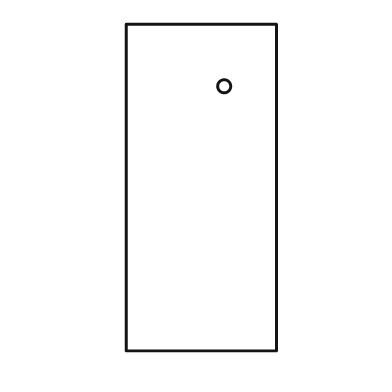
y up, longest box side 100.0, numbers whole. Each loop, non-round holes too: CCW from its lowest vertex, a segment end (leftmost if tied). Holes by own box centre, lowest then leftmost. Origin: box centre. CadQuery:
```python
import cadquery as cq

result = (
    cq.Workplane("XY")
    .moveTo(-23.0, -50.0)
    .lineTo(23.0, -50.0)
    .lineTo(23.0, 50.0)
    .lineTo(-23.0, 50.0)
    .close()
    .moveTo(7.0, 31.0)
    .circle(2.0)
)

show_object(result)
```